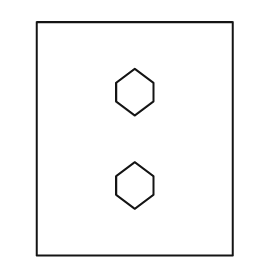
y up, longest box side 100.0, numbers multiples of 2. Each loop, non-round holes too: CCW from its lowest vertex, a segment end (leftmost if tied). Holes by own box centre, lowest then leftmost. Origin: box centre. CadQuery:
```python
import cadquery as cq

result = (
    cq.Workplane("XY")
    .moveTo(-42.0, -50.0)
    .lineTo(42.0, -50.0)
    .lineTo(42.0, 50.0)
    .lineTo(-42.0, 50.0)
    .close()
    .moveTo(0.0, -30.0)
    .lineTo(8.0, -24.0)
    .lineTo(8.0, -16.0)
    .lineTo(0.0, -10.0)
    .lineTo(-8.0, -16.0)
    .lineTo(-8.0, -24.0)
    .close()
    .moveTo(0.0, 10.0)
    .lineTo(8.0, 16.0)
    .lineTo(8.0, 24.0)
    .lineTo(0.0, 30.0)
    .lineTo(-8.0, 24.0)
    .lineTo(-8.0, 16.0)
    .close()
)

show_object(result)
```